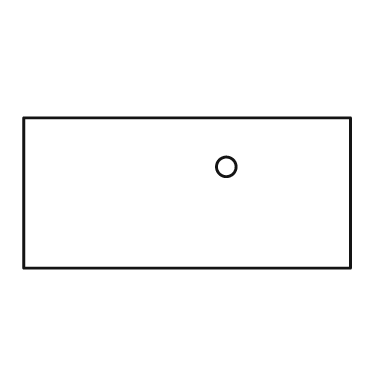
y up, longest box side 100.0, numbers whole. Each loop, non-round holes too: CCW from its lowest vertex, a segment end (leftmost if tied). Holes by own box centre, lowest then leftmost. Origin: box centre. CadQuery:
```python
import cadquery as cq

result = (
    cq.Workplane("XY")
    .moveTo(-50.0, -23.0)
    .lineTo(50.0, -23.0)
    .lineTo(50.0, 23.0)
    .lineTo(-50.0, 23.0)
    .close()
    .moveTo(12.0, 8.0)
    .circle(3.0)
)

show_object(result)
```